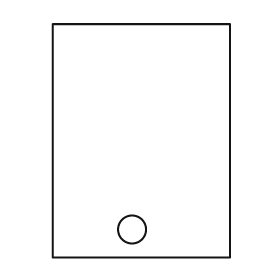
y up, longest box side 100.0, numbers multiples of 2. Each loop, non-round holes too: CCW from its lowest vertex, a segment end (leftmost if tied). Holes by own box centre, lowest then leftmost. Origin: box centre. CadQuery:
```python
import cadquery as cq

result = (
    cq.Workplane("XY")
    .moveTo(-38.0, -50.0)
    .lineTo(38.0, -50.0)
    .lineTo(38.0, 50.0)
    .lineTo(-38.0, 50.0)
    .close()
    .moveTo(-4.0, -38.0)
    .circle(6.0)
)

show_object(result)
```